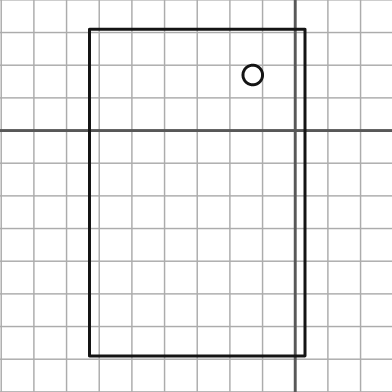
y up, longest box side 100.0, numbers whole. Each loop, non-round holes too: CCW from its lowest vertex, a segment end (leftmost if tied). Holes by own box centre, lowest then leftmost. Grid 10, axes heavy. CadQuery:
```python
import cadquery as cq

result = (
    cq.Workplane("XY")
    .moveTo(-63.0, -69.0)
    .lineTo(3.0, -69.0)
    .lineTo(3.0, 31.0)
    .lineTo(-63.0, 31.0)
    .close()
    .moveTo(-13.0, 17.0)
    .circle(3.0)
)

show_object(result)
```